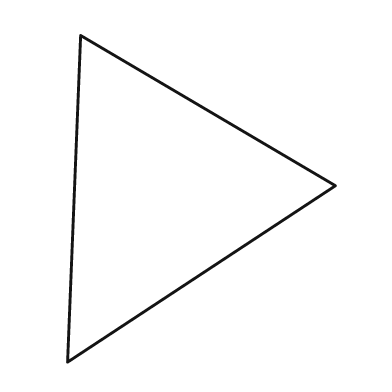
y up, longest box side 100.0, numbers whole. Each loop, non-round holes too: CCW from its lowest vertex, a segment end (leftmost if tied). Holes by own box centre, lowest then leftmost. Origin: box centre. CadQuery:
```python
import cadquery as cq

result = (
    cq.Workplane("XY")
    .moveTo(-41.0, -50.0)
    .lineTo(41.0, 4.0)
    .lineTo(-37.0, 50.0)
    .close()
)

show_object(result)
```